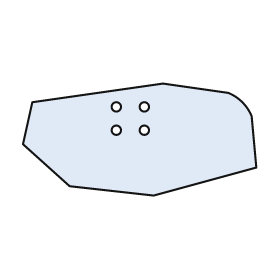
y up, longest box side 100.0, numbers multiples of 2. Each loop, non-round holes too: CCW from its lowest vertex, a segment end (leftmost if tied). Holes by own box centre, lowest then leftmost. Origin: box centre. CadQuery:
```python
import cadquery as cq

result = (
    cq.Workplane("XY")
    .moveTo(6.0, -24.0)
    .lineTo(50.0, -12.0)
    .lineTo(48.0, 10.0)
    .threePointArc((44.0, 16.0), (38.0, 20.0))
    .lineTo(10.0, 24.0)
    .lineTo(-46.0, 16.0)
    .lineTo(-50.0, -2.0)
    .lineTo(-30.0, -20.0)
    .close()
    .moveTo(-10.0, 4.0)
    .circle(2.0)
    .moveTo(2.0, 4.0)
    .circle(2.0)
    .moveTo(-10.0, 14.0)
    .circle(2.0)
    .moveTo(2.0, 14.0)
    .circle(2.0)
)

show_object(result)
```